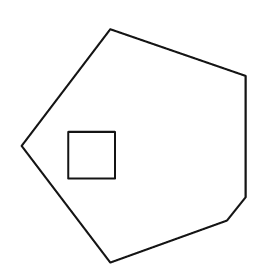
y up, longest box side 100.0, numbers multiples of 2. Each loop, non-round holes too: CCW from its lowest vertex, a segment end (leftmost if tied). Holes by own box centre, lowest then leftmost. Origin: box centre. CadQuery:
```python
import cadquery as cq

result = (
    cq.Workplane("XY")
    .moveTo(-10.0, -50.0)
    .lineTo(40.0, -32.0)
    .lineTo(48.0, -22.0)
    .lineTo(48.0, 30.0)
    .lineTo(-10.0, 50.0)
    .lineTo(-48.0, 0.0)
    .close()
    .moveTo(-28.0, -14.0)
    .lineTo(-8.0, -14.0)
    .lineTo(-8.0, 6.0)
    .lineTo(-28.0, 6.0)
    .close()
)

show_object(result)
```